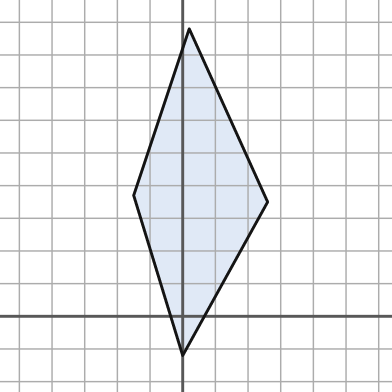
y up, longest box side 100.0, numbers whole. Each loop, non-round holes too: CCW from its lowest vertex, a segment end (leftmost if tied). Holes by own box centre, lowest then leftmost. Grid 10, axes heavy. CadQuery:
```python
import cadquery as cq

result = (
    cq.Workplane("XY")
    .moveTo(0.0, -12.0)
    .lineTo(26.0, 35.0)
    .lineTo(2.0, 88.0)
    .lineTo(-15.0, 37.0)
    .close()
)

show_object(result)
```